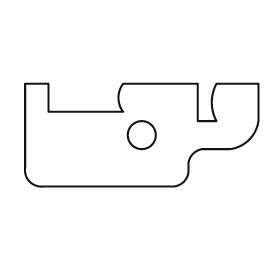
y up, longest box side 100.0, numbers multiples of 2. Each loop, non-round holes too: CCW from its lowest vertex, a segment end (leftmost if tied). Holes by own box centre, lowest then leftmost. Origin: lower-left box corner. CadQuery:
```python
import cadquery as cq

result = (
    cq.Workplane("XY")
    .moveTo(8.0, 0.0)
    .lineTo(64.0, 0.0)
    .threePointArc((68.0, 2.0), (70.0, 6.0))
    .lineTo(70.0, 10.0)
    .threePointArc((72.0, 14.0), (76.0, 16.0))
    .lineTo(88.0, 16.0)
    .threePointArc((96.0, 20.0), (100.0, 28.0))
    .lineTo(100.0, 44.0)
    .lineTo(82.0, 44.0)
    .threePointArc((80.0, 36.0), (82.0, 28.0))
    .lineTo(74.0, 28.0)
    .lineTo(74.0, 44.0)
    .lineTo(42.0, 44.0)
    .threePointArc((40.0, 38.0), (42.0, 32.0))
    .lineTo(10.0, 32.0)
    .lineTo(10.0, 44.0)
    .lineTo(0.0, 44.0)
    .lineTo(0.0, 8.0)
    .threePointArc((2.0, 2.0), (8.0, 0.0))
    .close()
    .moveTo(50.0, 22.0)
    .circle(6.0)
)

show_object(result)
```